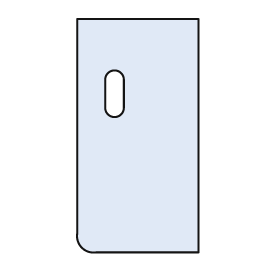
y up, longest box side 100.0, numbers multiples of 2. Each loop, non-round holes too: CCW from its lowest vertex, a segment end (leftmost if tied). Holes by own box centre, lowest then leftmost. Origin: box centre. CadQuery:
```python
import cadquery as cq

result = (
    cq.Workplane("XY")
    .moveTo(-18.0, -50.0)
    .lineTo(26.0, -50.0)
    .lineTo(26.0, 50.0)
    .lineTo(-26.0, 50.0)
    .lineTo(-26.0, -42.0)
    .threePointArc((-24.0, -48.0), (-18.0, -50.0))
    .close()
    .moveTo(-14.0, 12.0)
    .threePointArc((-10.0, 8.0), (-6.0, 12.0))
    .lineTo(-6.0, 24.0)
    .threePointArc((-10.0, 28.0), (-14.0, 24.0))
    .close()
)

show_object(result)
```